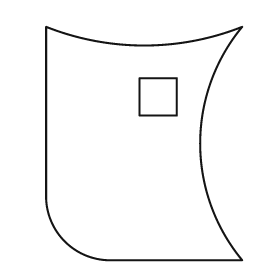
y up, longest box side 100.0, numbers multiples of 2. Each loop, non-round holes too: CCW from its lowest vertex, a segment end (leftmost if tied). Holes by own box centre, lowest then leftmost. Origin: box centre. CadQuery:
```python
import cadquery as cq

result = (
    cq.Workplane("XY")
    .moveTo(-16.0, -50.0)
    .lineTo(42.0, -50.0)
    .threePointArc((24.0, 0.0), (42.0, 50.0))
    .threePointArc((0.0, 42.0), (-42.0, 50.0))
    .lineTo(-42.0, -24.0)
    .threePointArc((-34.0, -42.0), (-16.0, -50.0))
    .close()
    .moveTo(-2.0, 12.0)
    .lineTo(14.0, 12.0)
    .lineTo(14.0, 28.0)
    .lineTo(-2.0, 28.0)
    .close()
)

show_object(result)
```